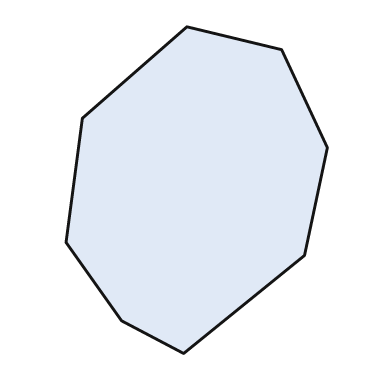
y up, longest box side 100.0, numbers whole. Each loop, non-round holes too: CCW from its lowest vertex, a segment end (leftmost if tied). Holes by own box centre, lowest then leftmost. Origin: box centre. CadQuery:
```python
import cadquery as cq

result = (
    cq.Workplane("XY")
    .moveTo(-4.0, -50.0)
    .lineTo(33.0, -20.0)
    .lineTo(40.0, 13.0)
    .lineTo(26.0, 43.0)
    .lineTo(-3.0, 50.0)
    .lineTo(-35.0, 22.0)
    .lineTo(-40.0, -16.0)
    .lineTo(-23.0, -40.0)
    .close()
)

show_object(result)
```